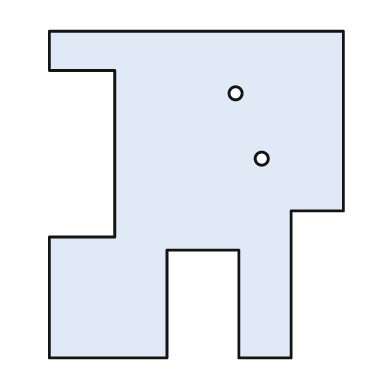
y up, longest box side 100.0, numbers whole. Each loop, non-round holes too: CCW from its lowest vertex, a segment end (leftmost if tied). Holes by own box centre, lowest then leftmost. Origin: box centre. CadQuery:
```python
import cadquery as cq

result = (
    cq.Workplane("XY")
    .moveTo(-45.0, -50.0)
    .lineTo(-9.0, -50.0)
    .lineTo(-9.0, -17.0)
    .lineTo(13.0, -17.0)
    .lineTo(13.0, -50.0)
    .lineTo(29.0, -50.0)
    .lineTo(29.0, -5.0)
    .lineTo(45.0, -5.0)
    .lineTo(45.0, 50.0)
    .lineTo(-45.0, 50.0)
    .lineTo(-45.0, 38.0)
    .lineTo(-25.0, 38.0)
    .lineTo(-25.0, -13.0)
    .lineTo(-45.0, -13.0)
    .close()
    .moveTo(20.0, 11.0)
    .circle(2.0)
    .moveTo(12.0, 31.0)
    .circle(2.0)
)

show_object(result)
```